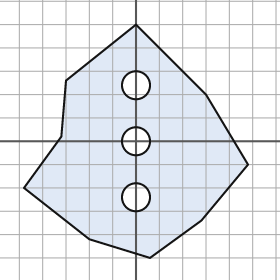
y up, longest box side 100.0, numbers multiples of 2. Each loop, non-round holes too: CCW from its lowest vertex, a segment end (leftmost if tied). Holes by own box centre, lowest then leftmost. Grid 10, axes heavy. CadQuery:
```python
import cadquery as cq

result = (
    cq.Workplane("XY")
    .moveTo(6.0, -50.0)
    .lineTo(28.0, -34.0)
    .lineTo(48.0, -10.0)
    .lineTo(30.0, 20.0)
    .lineTo(0.0, 50.0)
    .lineTo(-30.0, 26.0)
    .lineTo(-32.0, 2.0)
    .lineTo(-48.0, -20.0)
    .lineTo(-20.0, -42.0)
    .close()
    .moveTo(0.0, -24.0)
    .circle(6.0)
    .moveTo(0.0, 0.0)
    .circle(6.0)
    .moveTo(0.0, 24.0)
    .circle(6.0)
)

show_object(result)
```